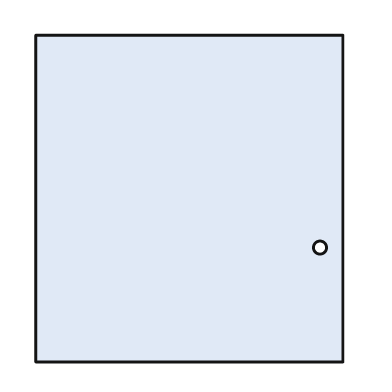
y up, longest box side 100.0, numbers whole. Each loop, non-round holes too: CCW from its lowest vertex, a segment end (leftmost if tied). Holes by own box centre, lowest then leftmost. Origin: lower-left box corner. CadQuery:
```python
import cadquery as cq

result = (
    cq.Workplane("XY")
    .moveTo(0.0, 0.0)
    .lineTo(94.0, 0.0)
    .lineTo(94.0, 100.0)
    .lineTo(0.0, 100.0)
    .close()
    .moveTo(87.0, 35.0)
    .circle(2.0)
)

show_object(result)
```